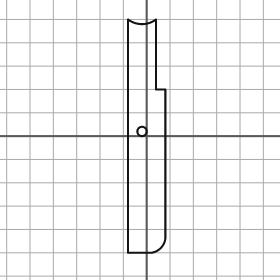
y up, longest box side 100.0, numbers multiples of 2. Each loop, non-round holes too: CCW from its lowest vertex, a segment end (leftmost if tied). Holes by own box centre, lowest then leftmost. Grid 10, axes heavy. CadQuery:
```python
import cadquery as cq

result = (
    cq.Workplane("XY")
    .moveTo(-8.0, -50.0)
    .lineTo(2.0, -50.0)
    .threePointArc((6.0, -48.0), (8.0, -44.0))
    .lineTo(8.0, 20.0)
    .lineTo(4.0, 20.0)
    .lineTo(4.0, 50.0)
    .threePointArc((-2.0, 48.0), (-8.0, 50.0))
    .close()
    .moveTo(-2.0, 2.0)
    .circle(2.0)
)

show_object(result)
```